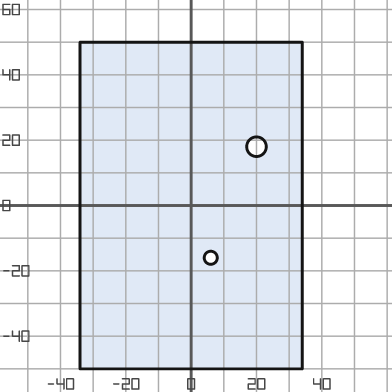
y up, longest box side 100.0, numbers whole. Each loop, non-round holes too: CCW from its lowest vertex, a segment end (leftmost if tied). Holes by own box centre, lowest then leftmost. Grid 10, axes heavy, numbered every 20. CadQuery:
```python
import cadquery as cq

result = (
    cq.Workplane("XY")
    .moveTo(-34.0, -50.0)
    .lineTo(34.0, -50.0)
    .lineTo(34.0, 50.0)
    .lineTo(-34.0, 50.0)
    .close()
    .moveTo(6.0, -16.0)
    .circle(2.0)
    .moveTo(20.0, 18.0)
    .circle(3.0)
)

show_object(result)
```